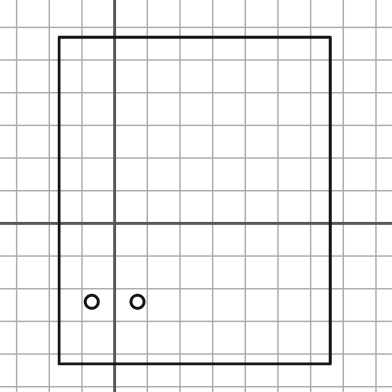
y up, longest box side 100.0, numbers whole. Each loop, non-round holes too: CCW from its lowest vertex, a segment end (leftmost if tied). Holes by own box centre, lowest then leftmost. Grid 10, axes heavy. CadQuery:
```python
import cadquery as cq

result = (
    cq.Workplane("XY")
    .moveTo(-17.0, -43.0)
    .lineTo(66.0, -43.0)
    .lineTo(66.0, 57.0)
    .lineTo(-17.0, 57.0)
    .close()
    .moveTo(-7.0, -24.0)
    .circle(2.0)
    .moveTo(7.0, -24.0)
    .circle(2.0)
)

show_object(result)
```